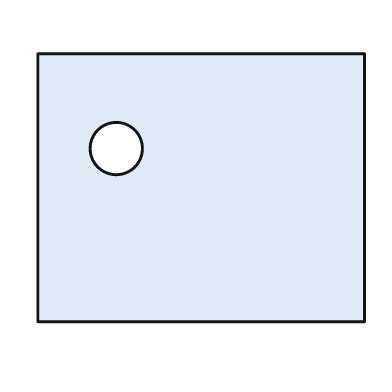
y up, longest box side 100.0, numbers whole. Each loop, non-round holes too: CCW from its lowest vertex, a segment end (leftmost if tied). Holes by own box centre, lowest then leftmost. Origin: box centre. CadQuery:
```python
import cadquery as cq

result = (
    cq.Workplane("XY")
    .moveTo(-50.0, -41.0)
    .lineTo(50.0, -41.0)
    .lineTo(50.0, 41.0)
    .lineTo(-50.0, 41.0)
    .close()
    .moveTo(-26.0, 12.0)
    .circle(8.0)
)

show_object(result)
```